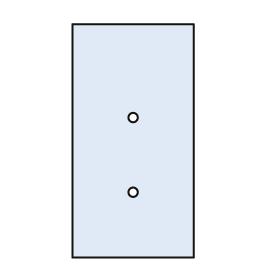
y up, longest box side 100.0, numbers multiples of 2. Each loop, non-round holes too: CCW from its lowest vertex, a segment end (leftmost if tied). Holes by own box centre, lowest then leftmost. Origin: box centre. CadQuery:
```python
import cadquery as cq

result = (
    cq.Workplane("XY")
    .moveTo(-26.0, -50.0)
    .lineTo(26.0, -50.0)
    .lineTo(26.0, 50.0)
    .lineTo(-26.0, 50.0)
    .close()
    .moveTo(0.0, -22.0)
    .circle(2.0)
    .moveTo(0.0, 10.0)
    .circle(2.0)
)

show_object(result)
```